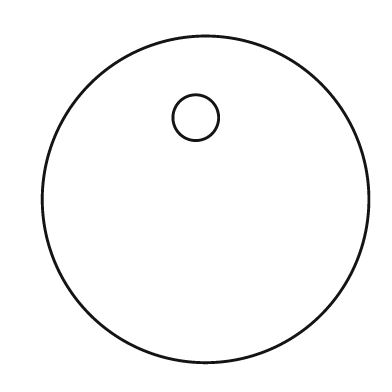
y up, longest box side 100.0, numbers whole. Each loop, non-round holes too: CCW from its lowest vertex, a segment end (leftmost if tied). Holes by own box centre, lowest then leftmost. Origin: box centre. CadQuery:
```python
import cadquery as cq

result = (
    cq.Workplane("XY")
    .moveTo(0.0, 0.0)
    .circle(50.0)
    .moveTo(-3.0, 25.0)
    .circle(7.0)
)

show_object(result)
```